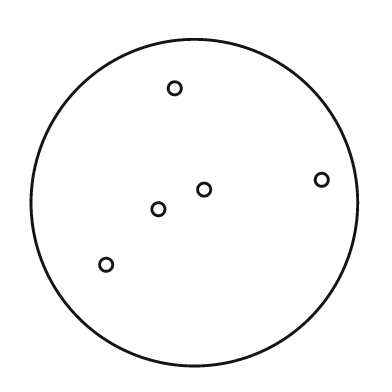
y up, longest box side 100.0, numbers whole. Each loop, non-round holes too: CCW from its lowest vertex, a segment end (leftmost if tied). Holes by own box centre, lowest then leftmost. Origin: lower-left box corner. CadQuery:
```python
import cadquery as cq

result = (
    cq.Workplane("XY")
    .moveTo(50.0, 50.0)
    .circle(50.0)
    .moveTo(23.0, 31.0)
    .circle(2.0)
    .moveTo(39.0, 48.0)
    .circle(2.0)
    .moveTo(53.0, 54.0)
    .circle(2.0)
    .moveTo(89.0, 57.0)
    .circle(2.0)
    .moveTo(44.0, 85.0)
    .circle(2.0)
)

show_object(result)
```